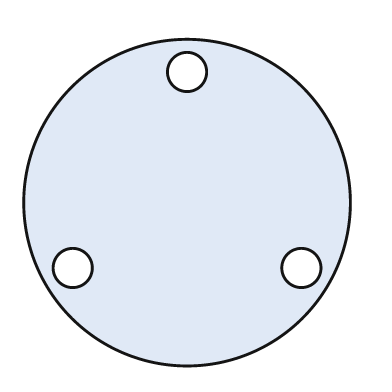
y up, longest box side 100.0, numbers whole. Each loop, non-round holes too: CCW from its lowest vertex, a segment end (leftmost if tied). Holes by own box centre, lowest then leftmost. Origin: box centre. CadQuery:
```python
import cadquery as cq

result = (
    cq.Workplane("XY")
    .moveTo(0.0, 0.0)
    .circle(50.0)
    .moveTo(-35.0, -20.0)
    .circle(6.0)
    .moveTo(35.0, -20.0)
    .circle(6.0)
    .moveTo(0.0, 40.0)
    .circle(6.0)
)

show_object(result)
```